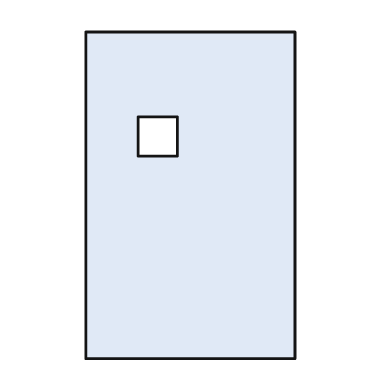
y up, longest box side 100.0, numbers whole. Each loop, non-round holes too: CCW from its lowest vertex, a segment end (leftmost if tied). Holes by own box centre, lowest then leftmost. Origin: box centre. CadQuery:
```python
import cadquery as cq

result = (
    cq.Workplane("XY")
    .moveTo(-32.0, -50.0)
    .lineTo(32.0, -50.0)
    .lineTo(32.0, 50.0)
    .lineTo(-32.0, 50.0)
    .close()
    .moveTo(-16.0, 12.0)
    .lineTo(-4.0, 12.0)
    .lineTo(-4.0, 24.0)
    .lineTo(-16.0, 24.0)
    .close()
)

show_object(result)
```